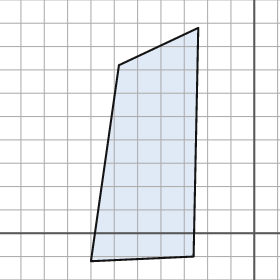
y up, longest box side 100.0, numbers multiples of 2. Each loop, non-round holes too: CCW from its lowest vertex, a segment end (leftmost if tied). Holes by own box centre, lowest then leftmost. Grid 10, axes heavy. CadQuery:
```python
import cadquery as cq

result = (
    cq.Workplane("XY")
    .moveTo(-70.0, -12.0)
    .lineTo(-26.0, -10.0)
    .lineTo(-24.0, 88.0)
    .lineTo(-58.0, 72.0)
    .close()
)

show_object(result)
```